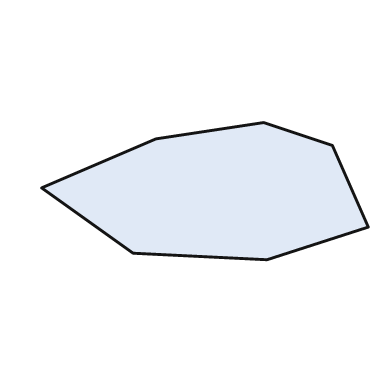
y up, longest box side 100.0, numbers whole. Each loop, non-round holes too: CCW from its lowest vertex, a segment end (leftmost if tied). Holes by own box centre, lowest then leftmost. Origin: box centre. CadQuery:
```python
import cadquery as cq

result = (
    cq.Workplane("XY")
    .moveTo(19.0, -21.0)
    .lineTo(50.0, -11.0)
    .lineTo(39.0, 14.0)
    .lineTo(18.0, 21.0)
    .lineTo(-15.0, 16.0)
    .lineTo(-50.0, 1.0)
    .lineTo(-22.0, -19.0)
    .close()
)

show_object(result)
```